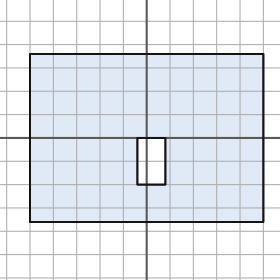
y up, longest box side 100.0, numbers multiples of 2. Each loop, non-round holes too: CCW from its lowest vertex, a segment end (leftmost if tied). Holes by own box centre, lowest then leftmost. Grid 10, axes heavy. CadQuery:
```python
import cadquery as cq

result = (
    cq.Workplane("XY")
    .moveTo(-50.0, -36.0)
    .lineTo(50.0, -36.0)
    .lineTo(50.0, 36.0)
    .lineTo(-50.0, 36.0)
    .close()
    .moveTo(-4.0, -20.0)
    .lineTo(8.0, -20.0)
    .lineTo(8.0, 0.0)
    .lineTo(-4.0, 0.0)
    .close()
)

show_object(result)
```